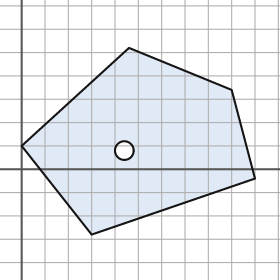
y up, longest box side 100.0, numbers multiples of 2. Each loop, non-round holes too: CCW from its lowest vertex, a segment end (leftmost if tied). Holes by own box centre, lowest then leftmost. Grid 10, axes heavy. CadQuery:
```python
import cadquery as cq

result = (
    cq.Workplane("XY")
    .moveTo(30.0, -28.0)
    .lineTo(100.0, -4.0)
    .lineTo(90.0, 34.0)
    .lineTo(46.0, 52.0)
    .lineTo(0.0, 10.0)
    .close()
    .moveTo(44.0, 8.0)
    .circle(4.0)
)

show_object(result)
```